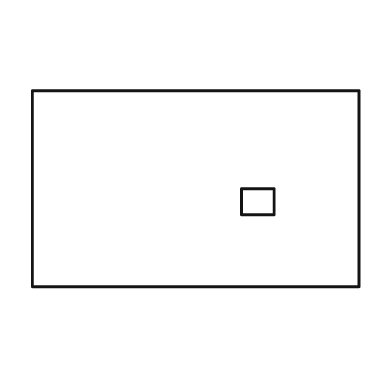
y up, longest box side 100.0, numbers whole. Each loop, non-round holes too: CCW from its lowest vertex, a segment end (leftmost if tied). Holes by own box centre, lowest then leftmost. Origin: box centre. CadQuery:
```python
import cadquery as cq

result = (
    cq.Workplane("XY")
    .moveTo(-50.0, -30.0)
    .lineTo(50.0, -30.0)
    .lineTo(50.0, 30.0)
    .lineTo(-50.0, 30.0)
    .close()
    .moveTo(14.0, -8.0)
    .lineTo(24.0, -8.0)
    .lineTo(24.0, 0.0)
    .lineTo(14.0, 0.0)
    .close()
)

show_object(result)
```